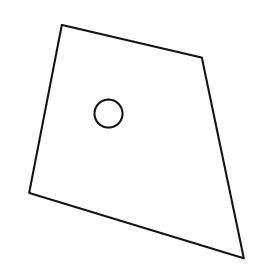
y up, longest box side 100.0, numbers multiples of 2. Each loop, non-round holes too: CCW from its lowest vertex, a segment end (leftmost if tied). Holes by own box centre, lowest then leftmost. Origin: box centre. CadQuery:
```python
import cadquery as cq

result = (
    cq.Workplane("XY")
    .moveTo(46.0, -50.0)
    .lineTo(28.0, 36.0)
    .lineTo(-32.0, 50.0)
    .lineTo(-46.0, -22.0)
    .close()
    .moveTo(-12.0, 12.0)
    .circle(6.0)
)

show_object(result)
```